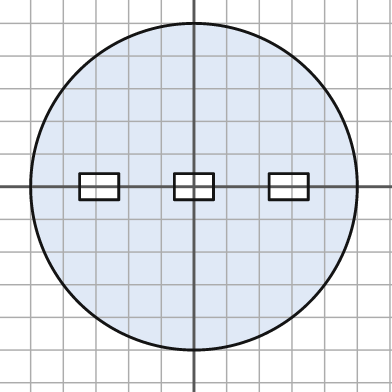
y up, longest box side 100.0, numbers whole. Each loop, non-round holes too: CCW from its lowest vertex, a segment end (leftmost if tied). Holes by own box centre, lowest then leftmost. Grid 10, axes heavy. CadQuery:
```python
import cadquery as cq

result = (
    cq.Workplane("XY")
    .moveTo(0.0, 0.0)
    .circle(50.0)
    .moveTo(-35.0, -4.0)
    .lineTo(-23.0, -4.0)
    .lineTo(-23.0, 4.0)
    .lineTo(-35.0, 4.0)
    .close()
    .moveTo(-6.0, -4.0)
    .lineTo(6.0, -4.0)
    .lineTo(6.0, 4.0)
    .lineTo(-6.0, 4.0)
    .close()
    .moveTo(23.0, -4.0)
    .lineTo(35.0, -4.0)
    .lineTo(35.0, 4.0)
    .lineTo(23.0, 4.0)
    .close()
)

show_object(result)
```